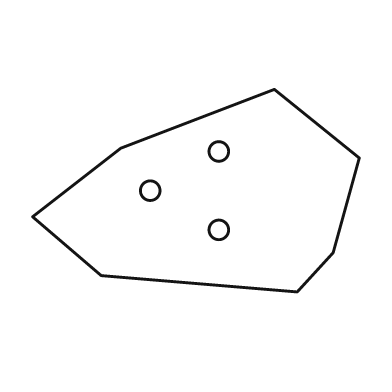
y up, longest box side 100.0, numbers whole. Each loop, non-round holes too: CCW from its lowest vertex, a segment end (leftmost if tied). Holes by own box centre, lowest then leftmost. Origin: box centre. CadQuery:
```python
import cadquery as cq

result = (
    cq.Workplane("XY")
    .moveTo(31.0, -31.0)
    .lineTo(42.0, -19.0)
    .lineTo(50.0, 10.0)
    .lineTo(24.0, 31.0)
    .lineTo(-23.0, 13.0)
    .lineTo(-50.0, -8.0)
    .lineTo(-29.0, -26.0)
    .close()
    .moveTo(7.0, -12.0)
    .circle(3.0)
    .moveTo(-14.0, 0.0)
    .circle(3.0)
    .moveTo(7.0, 12.0)
    .circle(3.0)
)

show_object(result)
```